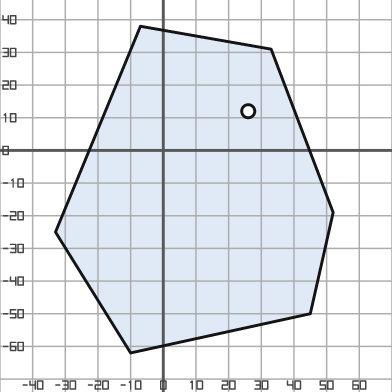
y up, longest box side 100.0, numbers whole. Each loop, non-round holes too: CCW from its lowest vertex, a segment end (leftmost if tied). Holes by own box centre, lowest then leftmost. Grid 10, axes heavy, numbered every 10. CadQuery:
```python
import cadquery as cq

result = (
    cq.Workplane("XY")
    .moveTo(-10.0, -62.0)
    .lineTo(45.0, -50.0)
    .lineTo(52.0, -19.0)
    .lineTo(33.0, 31.0)
    .lineTo(-7.0, 38.0)
    .lineTo(-33.0, -25.0)
    .close()
    .moveTo(26.0, 12.0)
    .circle(2.0)
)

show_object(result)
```